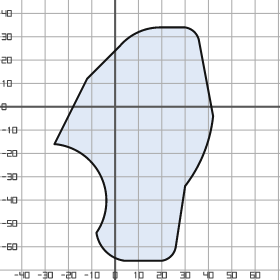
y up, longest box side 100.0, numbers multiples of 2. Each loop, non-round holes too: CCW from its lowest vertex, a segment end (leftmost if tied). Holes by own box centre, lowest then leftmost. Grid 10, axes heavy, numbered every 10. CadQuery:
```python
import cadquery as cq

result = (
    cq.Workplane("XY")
    .moveTo(4.0, -66.0)
    .lineTo(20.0, -66.0)
    .threePointArc((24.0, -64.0), (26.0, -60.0))
    .lineTo(30.0, -34.0)
    .threePointArc((38.0, -20.0), (42.0, -4.0))
    .lineTo(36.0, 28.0)
    .threePointArc((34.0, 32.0), (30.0, 34.0))
    .lineTo(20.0, 34.0)
    .threePointArc((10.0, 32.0), (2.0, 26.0))
    .lineTo(-12.0, 12.0)
    .lineTo(-26.0, -16.0)
    .threePointArc((-6.0, -30.0), (-8.0, -54.0))
    .threePointArc((-4.0, -62.0), (4.0, -66.0))
    .close()
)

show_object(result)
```